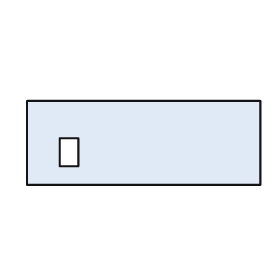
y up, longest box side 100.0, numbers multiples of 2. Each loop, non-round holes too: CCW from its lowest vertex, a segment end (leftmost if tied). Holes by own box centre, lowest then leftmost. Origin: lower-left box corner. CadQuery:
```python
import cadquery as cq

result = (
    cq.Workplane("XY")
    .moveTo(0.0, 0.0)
    .lineTo(100.0, 0.0)
    .lineTo(100.0, 36.0)
    .lineTo(0.0, 36.0)
    .close()
    .moveTo(14.0, 8.0)
    .lineTo(22.0, 8.0)
    .lineTo(22.0, 20.0)
    .lineTo(14.0, 20.0)
    .close()
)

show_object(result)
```